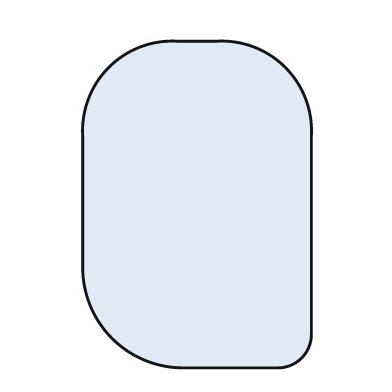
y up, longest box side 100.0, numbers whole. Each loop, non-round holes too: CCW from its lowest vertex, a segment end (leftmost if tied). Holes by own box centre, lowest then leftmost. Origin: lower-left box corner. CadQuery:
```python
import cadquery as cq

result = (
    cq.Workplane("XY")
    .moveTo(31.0, 0.0)
    .lineTo(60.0, 0.0)
    .threePointArc((67.0, 3.0), (70.0, 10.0))
    .lineTo(70.0, 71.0)
    .threePointArc((62.0, 92.0), (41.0, 100.0))
    .lineTo(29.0, 100.0)
    .threePointArc((8.0, 92.0), (0.0, 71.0))
    .lineTo(0.0, 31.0)
    .threePointArc((9.0, 9.0), (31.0, 0.0))
    .close()
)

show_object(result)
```